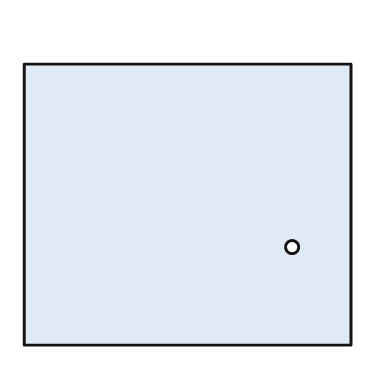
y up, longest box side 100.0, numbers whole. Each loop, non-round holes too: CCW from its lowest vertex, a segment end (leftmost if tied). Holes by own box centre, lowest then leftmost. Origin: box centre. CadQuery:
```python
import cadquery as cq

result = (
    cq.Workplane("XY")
    .moveTo(-50.0, -43.0)
    .lineTo(50.0, -43.0)
    .lineTo(50.0, 43.0)
    .lineTo(-50.0, 43.0)
    .close()
    .moveTo(32.0, -13.0)
    .circle(2.0)
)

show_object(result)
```